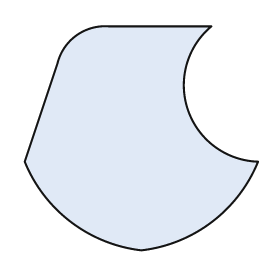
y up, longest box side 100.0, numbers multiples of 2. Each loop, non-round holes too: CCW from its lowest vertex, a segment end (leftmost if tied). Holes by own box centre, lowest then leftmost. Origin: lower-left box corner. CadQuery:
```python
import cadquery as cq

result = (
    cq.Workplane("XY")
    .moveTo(50.0, 0.0)
    .threePointArc((80.0, 12.0), (100.0, 38.0))
    .threePointArc((70.0, 60.0), (80.0, 96.0))
    .lineTo(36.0, 96.0)
    .threePointArc((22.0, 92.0), (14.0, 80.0))
    .lineTo(0.0, 38.0)
    .threePointArc((20.0, 12.0), (50.0, 0.0))
    .close()
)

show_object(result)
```